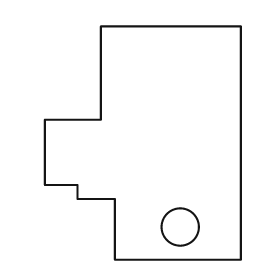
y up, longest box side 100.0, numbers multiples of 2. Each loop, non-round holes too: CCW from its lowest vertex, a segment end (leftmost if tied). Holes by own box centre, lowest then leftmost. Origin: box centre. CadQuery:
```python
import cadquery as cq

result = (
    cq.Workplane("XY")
    .moveTo(-12.0, -50.0)
    .lineTo(42.0, -50.0)
    .lineTo(42.0, 50.0)
    .lineTo(-18.0, 50.0)
    .lineTo(-18.0, 10.0)
    .lineTo(-42.0, 10.0)
    .lineTo(-42.0, -18.0)
    .lineTo(-28.0, -18.0)
    .lineTo(-28.0, -24.0)
    .lineTo(-12.0, -24.0)
    .close()
    .moveTo(16.0, -36.0)
    .circle(8.0)
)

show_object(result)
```